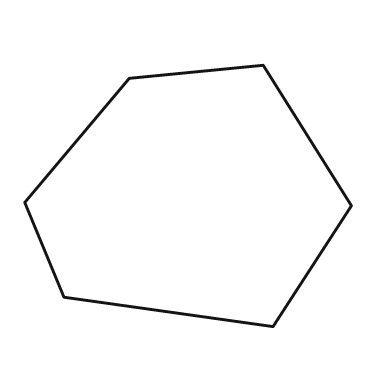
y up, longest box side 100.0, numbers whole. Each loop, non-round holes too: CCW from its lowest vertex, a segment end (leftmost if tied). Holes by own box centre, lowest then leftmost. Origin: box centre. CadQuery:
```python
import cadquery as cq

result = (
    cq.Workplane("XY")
    .moveTo(26.0, -40.0)
    .lineTo(50.0, -3.0)
    .lineTo(23.0, 40.0)
    .lineTo(-18.0, 36.0)
    .lineTo(-50.0, -2.0)
    .lineTo(-38.0, -31.0)
    .close()
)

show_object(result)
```